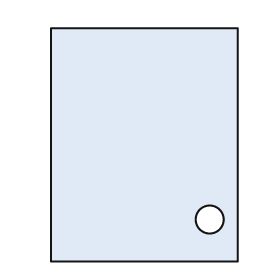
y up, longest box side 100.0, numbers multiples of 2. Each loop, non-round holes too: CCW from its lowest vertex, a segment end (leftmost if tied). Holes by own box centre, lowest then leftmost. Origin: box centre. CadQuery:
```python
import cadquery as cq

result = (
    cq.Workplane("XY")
    .moveTo(-40.0, -50.0)
    .lineTo(40.0, -50.0)
    .lineTo(40.0, 50.0)
    .lineTo(-40.0, 50.0)
    .close()
    .moveTo(28.0, -32.0)
    .circle(6.0)
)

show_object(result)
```